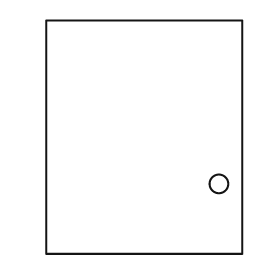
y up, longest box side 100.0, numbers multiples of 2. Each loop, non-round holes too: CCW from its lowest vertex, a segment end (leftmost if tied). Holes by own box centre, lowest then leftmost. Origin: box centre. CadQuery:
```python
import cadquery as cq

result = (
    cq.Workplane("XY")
    .moveTo(-42.0, -50.0)
    .lineTo(42.0, -50.0)
    .lineTo(42.0, 50.0)
    .lineTo(-42.0, 50.0)
    .close()
    .moveTo(32.0, -20.0)
    .circle(4.0)
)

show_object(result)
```